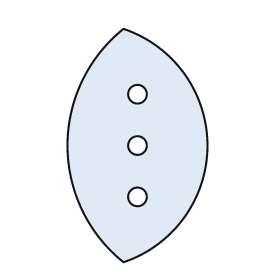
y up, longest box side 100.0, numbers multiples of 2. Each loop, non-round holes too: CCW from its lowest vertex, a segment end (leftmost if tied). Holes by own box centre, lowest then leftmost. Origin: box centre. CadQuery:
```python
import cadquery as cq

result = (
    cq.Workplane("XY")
    .moveTo(-6.0, -50.0)
    .threePointArc((30.0, 0.0), (-6.0, 50.0))
    .threePointArc((-30.0, 0.0), (-6.0, -50.0))
    .close()
    .moveTo(0.0, -22.0)
    .circle(4.0)
    .moveTo(0.0, 0.0)
    .circle(4.0)
    .moveTo(0.0, 22.0)
    .circle(4.0)
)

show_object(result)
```